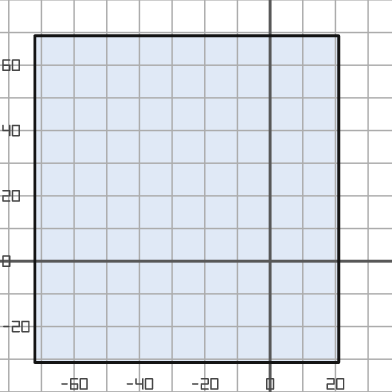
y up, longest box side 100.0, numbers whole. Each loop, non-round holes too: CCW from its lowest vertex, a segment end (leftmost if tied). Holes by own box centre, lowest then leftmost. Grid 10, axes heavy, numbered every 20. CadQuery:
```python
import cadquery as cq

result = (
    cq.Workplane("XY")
    .moveTo(-72.0, -31.0)
    .lineTo(21.0, -31.0)
    .lineTo(21.0, 69.0)
    .lineTo(-72.0, 69.0)
    .close()
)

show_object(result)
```